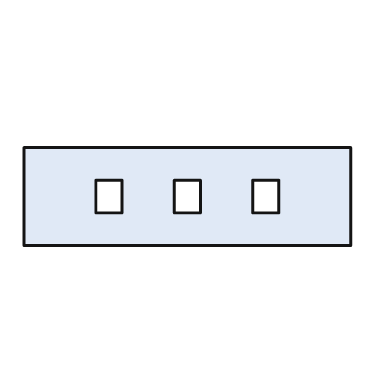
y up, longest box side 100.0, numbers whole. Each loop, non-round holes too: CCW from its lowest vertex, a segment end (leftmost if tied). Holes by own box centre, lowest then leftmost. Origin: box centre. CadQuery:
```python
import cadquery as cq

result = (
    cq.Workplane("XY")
    .moveTo(-50.0, -15.0)
    .lineTo(50.0, -15.0)
    .lineTo(50.0, 15.0)
    .lineTo(-50.0, 15.0)
    .close()
    .moveTo(-28.0, -5.0)
    .lineTo(-20.0, -5.0)
    .lineTo(-20.0, 5.0)
    .lineTo(-28.0, 5.0)
    .close()
    .moveTo(-4.0, -5.0)
    .lineTo(4.0, -5.0)
    .lineTo(4.0, 5.0)
    .lineTo(-4.0, 5.0)
    .close()
    .moveTo(20.0, -5.0)
    .lineTo(28.0, -5.0)
    .lineTo(28.0, 5.0)
    .lineTo(20.0, 5.0)
    .close()
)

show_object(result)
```